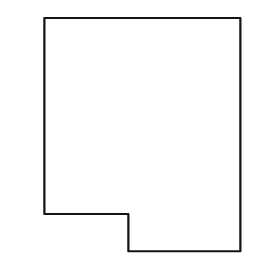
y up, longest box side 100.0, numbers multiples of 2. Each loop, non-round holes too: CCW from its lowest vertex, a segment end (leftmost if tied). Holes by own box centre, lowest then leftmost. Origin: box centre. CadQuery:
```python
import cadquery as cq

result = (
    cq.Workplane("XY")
    .moveTo(-6.0, -50.0)
    .lineTo(42.0, -50.0)
    .lineTo(42.0, 50.0)
    .lineTo(-42.0, 50.0)
    .lineTo(-42.0, -34.0)
    .lineTo(-6.0, -34.0)
    .close()
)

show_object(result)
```